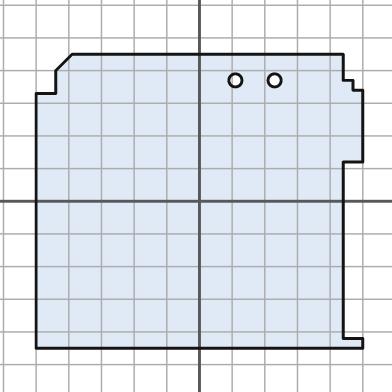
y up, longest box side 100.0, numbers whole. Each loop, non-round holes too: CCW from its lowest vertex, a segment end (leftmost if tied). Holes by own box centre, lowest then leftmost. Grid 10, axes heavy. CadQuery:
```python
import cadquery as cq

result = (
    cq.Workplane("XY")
    .moveTo(-50.0, -45.0)
    .lineTo(50.0, -45.0)
    .lineTo(50.0, -42.0)
    .lineTo(44.0, -42.0)
    .lineTo(44.0, 12.0)
    .lineTo(50.0, 12.0)
    .lineTo(50.0, 34.0)
    .lineTo(47.0, 34.0)
    .lineTo(47.0, 37.0)
    .lineTo(44.0, 37.0)
    .lineTo(44.0, 45.0)
    .lineTo(-39.0, 45.0)
    .lineTo(-44.0, 40.0)
    .lineTo(-44.0, 33.0)
    .lineTo(-50.0, 33.0)
    .close()
    .moveTo(11.0, 37.0)
    .circle(2.0)
    .moveTo(23.0, 37.0)
    .circle(2.0)
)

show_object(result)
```